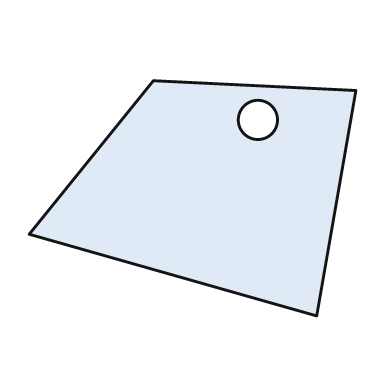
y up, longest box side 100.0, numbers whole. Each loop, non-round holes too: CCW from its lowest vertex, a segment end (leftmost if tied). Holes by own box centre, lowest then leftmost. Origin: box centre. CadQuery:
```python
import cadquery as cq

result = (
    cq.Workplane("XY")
    .moveTo(38.0, -36.0)
    .lineTo(50.0, 33.0)
    .lineTo(-12.0, 36.0)
    .lineTo(-50.0, -11.0)
    .close()
    .moveTo(20.0, 24.0)
    .circle(6.0)
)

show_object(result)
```